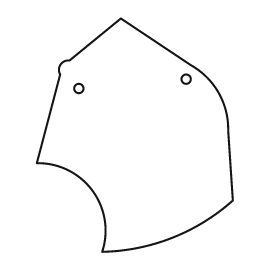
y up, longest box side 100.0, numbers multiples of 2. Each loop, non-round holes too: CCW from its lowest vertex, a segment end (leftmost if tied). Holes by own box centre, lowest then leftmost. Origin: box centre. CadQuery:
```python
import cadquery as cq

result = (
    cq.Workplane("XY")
    .moveTo(-14.0, -50.0)
    .threePointArc((16.0, -44.0), (42.0, -28.0))
    .lineTo(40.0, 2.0)
    .threePointArc((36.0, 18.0), (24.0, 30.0))
    .lineTo(-6.0, 50.0)
    .lineTo(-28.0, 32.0)
    .threePointArc((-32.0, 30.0), (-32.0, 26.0))
    .lineTo(-42.0, -12.0)
    .threePointArc((-18.0, -24.0), (-14.0, -50.0))
    .close()
    .moveTo(-24.0, 20.0)
    .circle(2.0)
    .moveTo(22.0, 24.0)
    .circle(2.0)
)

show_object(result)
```